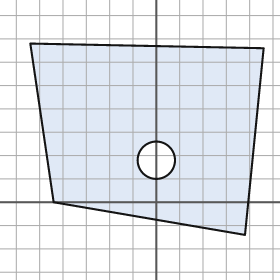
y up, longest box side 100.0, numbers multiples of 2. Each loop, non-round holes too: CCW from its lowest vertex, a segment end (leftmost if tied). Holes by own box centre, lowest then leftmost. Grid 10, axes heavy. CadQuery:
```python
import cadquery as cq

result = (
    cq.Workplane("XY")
    .moveTo(38.0, -14.0)
    .lineTo(46.0, 66.0)
    .lineTo(-54.0, 68.0)
    .lineTo(-44.0, 0.0)
    .close()
    .moveTo(0.0, 18.0)
    .circle(8.0)
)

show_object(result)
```